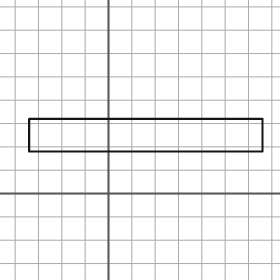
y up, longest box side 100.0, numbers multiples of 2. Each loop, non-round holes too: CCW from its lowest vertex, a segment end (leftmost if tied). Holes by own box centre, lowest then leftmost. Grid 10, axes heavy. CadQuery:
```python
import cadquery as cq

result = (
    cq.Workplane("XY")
    .moveTo(-34.0, 18.0)
    .lineTo(66.0, 18.0)
    .lineTo(66.0, 32.0)
    .lineTo(-34.0, 32.0)
    .close()
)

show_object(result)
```